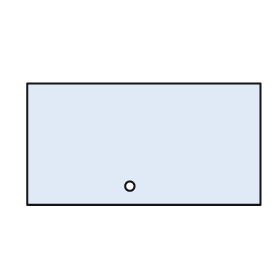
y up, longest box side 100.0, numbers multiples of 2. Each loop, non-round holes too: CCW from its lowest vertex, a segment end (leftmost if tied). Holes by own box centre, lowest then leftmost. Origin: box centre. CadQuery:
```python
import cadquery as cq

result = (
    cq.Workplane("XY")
    .moveTo(-50.0, -26.0)
    .lineTo(50.0, -26.0)
    .lineTo(50.0, 26.0)
    .lineTo(-50.0, 26.0)
    .close()
    .moveTo(-6.0, -18.0)
    .circle(2.0)
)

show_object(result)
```